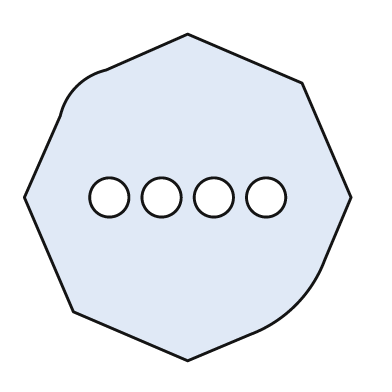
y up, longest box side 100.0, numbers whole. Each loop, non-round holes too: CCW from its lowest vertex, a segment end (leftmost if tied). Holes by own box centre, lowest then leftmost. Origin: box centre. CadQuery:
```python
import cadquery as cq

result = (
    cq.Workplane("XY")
    .moveTo(0.0, -50.0)
    .lineTo(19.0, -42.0)
    .threePointArc((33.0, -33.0), (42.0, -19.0))
    .lineTo(50.0, 0.0)
    .lineTo(35.0, 35.0)
    .lineTo(0.0, 50.0)
    .lineTo(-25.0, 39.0)
    .threePointArc((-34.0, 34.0), (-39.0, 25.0))
    .lineTo(-50.0, 0.0)
    .lineTo(-35.0, -35.0)
    .close()
    .moveTo(-24.0, 0.0)
    .circle(6.0)
    .moveTo(-8.0, 0.0)
    .circle(6.0)
    .moveTo(8.0, 0.0)
    .circle(6.0)
    .moveTo(24.0, 0.0)
    .circle(6.0)
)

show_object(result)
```